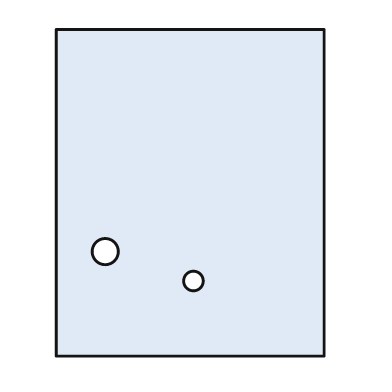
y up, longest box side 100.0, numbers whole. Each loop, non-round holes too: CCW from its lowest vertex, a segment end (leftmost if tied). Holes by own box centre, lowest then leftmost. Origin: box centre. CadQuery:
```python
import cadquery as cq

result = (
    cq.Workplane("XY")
    .moveTo(-41.0, -50.0)
    .lineTo(41.0, -50.0)
    .lineTo(41.0, 50.0)
    .lineTo(-41.0, 50.0)
    .close()
    .moveTo(1.0, -27.0)
    .circle(3.0)
    .moveTo(-26.0, -18.0)
    .circle(4.0)
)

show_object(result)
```